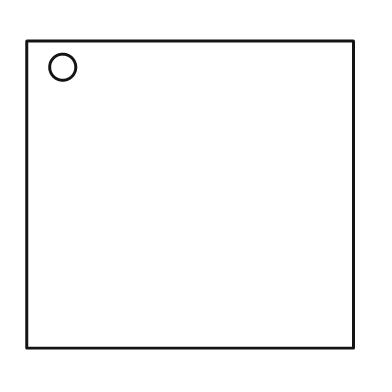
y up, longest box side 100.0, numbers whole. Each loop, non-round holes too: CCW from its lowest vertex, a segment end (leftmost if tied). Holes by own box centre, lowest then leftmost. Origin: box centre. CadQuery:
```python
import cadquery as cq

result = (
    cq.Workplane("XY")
    .moveTo(-50.0, -47.0)
    .lineTo(50.0, -47.0)
    .lineTo(50.0, 47.0)
    .lineTo(-50.0, 47.0)
    .close()
    .moveTo(-39.0, 39.0)
    .circle(4.0)
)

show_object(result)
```